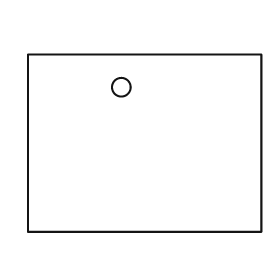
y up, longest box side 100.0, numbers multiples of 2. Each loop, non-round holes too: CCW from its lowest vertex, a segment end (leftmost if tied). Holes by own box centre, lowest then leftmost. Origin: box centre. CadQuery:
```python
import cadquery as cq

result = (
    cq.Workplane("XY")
    .moveTo(-50.0, -38.0)
    .lineTo(50.0, -38.0)
    .lineTo(50.0, 38.0)
    .lineTo(-50.0, 38.0)
    .close()
    .moveTo(-10.0, 24.0)
    .circle(4.0)
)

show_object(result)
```